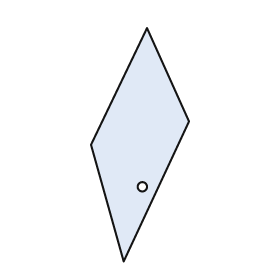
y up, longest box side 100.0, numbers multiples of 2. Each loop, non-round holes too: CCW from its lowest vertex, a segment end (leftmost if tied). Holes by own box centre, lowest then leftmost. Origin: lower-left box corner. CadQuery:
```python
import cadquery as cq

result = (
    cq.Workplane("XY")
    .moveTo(14.0, 0.0)
    .lineTo(42.0, 60.0)
    .lineTo(24.0, 100.0)
    .lineTo(0.0, 50.0)
    .close()
    .moveTo(22.0, 32.0)
    .circle(2.0)
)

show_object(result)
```